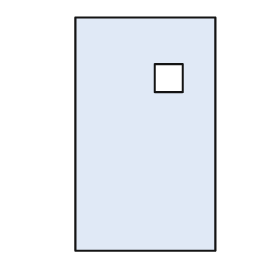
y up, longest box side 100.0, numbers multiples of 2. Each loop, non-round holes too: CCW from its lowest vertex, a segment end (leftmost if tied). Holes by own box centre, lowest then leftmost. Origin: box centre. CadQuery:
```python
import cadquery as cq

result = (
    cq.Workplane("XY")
    .moveTo(-30.0, -50.0)
    .lineTo(30.0, -50.0)
    .lineTo(30.0, 50.0)
    .lineTo(-30.0, 50.0)
    .close()
    .moveTo(4.0, 18.0)
    .lineTo(16.0, 18.0)
    .lineTo(16.0, 30.0)
    .lineTo(4.0, 30.0)
    .close()
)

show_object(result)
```